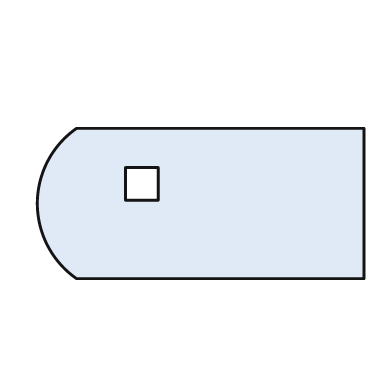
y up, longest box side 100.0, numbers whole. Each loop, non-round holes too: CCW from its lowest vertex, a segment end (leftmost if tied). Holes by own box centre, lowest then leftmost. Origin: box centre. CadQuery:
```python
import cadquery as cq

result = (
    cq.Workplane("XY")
    .moveTo(-38.0, -23.0)
    .lineTo(50.0, -23.0)
    .lineTo(50.0, 23.0)
    .lineTo(-38.0, 23.0)
    .threePointArc((-50.0, 0.0), (-38.0, -23.0))
    .close()
    .moveTo(-23.0, 1.0)
    .lineTo(-13.0, 1.0)
    .lineTo(-13.0, 11.0)
    .lineTo(-23.0, 11.0)
    .close()
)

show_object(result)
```